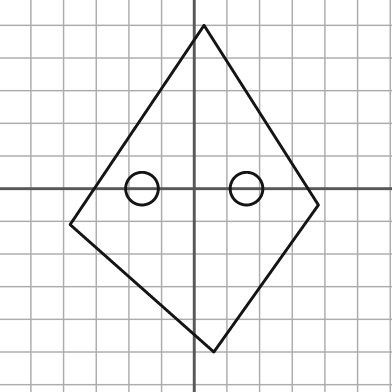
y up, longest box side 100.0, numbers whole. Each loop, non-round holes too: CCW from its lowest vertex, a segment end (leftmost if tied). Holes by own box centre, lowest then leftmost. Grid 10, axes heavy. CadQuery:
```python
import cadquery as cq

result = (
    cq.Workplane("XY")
    .moveTo(6.0, -50.0)
    .lineTo(38.0, -5.0)
    .lineTo(3.0, 50.0)
    .lineTo(-38.0, -11.0)
    .close()
    .moveTo(-16.0, 0.0)
    .circle(5.0)
    .moveTo(16.0, 0.0)
    .circle(5.0)
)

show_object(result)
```